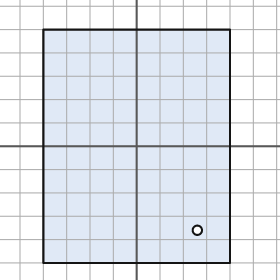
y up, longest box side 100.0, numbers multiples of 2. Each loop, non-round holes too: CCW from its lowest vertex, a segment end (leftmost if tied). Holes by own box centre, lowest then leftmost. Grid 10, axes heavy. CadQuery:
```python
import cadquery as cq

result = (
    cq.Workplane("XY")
    .moveTo(-40.0, -50.0)
    .lineTo(40.0, -50.0)
    .lineTo(40.0, 50.0)
    .lineTo(-40.0, 50.0)
    .close()
    .moveTo(26.0, -36.0)
    .circle(2.0)
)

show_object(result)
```